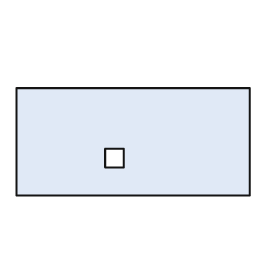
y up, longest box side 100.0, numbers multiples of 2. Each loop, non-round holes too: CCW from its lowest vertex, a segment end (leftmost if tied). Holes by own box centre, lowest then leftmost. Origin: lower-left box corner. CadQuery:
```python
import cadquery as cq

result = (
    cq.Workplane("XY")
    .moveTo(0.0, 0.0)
    .lineTo(100.0, 0.0)
    .lineTo(100.0, 46.0)
    .lineTo(0.0, 46.0)
    .close()
    .moveTo(38.0, 12.0)
    .lineTo(46.0, 12.0)
    .lineTo(46.0, 20.0)
    .lineTo(38.0, 20.0)
    .close()
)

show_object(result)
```